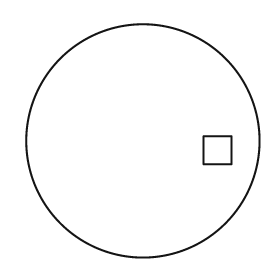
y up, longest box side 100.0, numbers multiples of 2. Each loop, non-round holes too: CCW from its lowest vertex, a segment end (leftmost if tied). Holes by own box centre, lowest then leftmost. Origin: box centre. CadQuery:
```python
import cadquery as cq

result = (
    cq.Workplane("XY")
    .moveTo(0.0, 0.0)
    .circle(50.0)
    .moveTo(26.0, -10.0)
    .lineTo(38.0, -10.0)
    .lineTo(38.0, 2.0)
    .lineTo(26.0, 2.0)
    .close()
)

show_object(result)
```